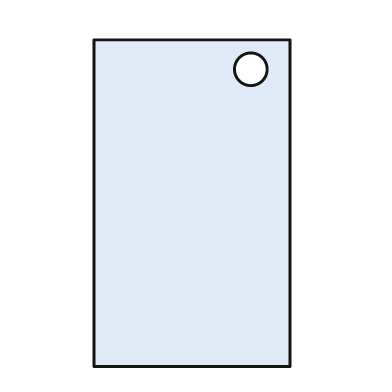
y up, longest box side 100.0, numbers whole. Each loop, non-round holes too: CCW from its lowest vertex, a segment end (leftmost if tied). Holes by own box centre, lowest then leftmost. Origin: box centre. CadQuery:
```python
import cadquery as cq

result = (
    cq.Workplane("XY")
    .moveTo(-30.0, -50.0)
    .lineTo(30.0, -50.0)
    .lineTo(30.0, 50.0)
    .lineTo(-30.0, 50.0)
    .close()
    .moveTo(18.0, 41.0)
    .circle(5.0)
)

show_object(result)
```